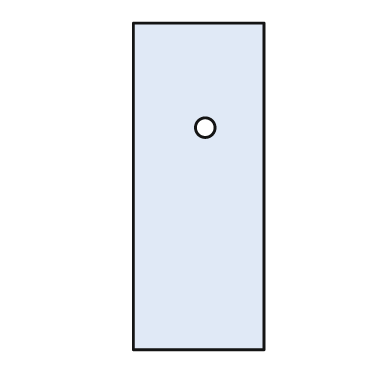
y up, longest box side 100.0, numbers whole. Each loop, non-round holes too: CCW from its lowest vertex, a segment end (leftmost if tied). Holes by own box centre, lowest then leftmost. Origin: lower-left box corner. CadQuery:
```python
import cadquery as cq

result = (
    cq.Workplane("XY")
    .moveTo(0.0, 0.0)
    .lineTo(40.0, 0.0)
    .lineTo(40.0, 100.0)
    .lineTo(0.0, 100.0)
    .close()
    .moveTo(22.0, 68.0)
    .circle(3.0)
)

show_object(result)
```